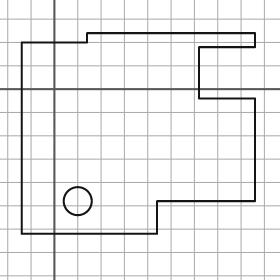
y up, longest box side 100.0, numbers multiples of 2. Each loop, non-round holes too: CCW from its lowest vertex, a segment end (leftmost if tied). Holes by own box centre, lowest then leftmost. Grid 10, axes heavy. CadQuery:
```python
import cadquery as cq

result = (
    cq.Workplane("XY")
    .moveTo(-14.0, -62.0)
    .lineTo(44.0, -62.0)
    .lineTo(44.0, -48.0)
    .lineTo(86.0, -48.0)
    .lineTo(86.0, -4.0)
    .lineTo(62.0, -4.0)
    .lineTo(62.0, 18.0)
    .lineTo(86.0, 18.0)
    .lineTo(86.0, 24.0)
    .lineTo(14.0, 24.0)
    .lineTo(14.0, 20.0)
    .lineTo(-14.0, 20.0)
    .close()
    .moveTo(10.0, -48.0)
    .circle(6.0)
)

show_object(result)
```